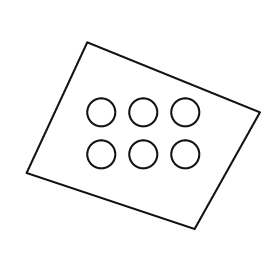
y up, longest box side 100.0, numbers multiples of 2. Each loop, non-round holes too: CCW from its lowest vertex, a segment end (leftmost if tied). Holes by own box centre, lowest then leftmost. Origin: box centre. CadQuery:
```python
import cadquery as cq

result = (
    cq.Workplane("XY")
    .moveTo(22.0, -40.0)
    .lineTo(50.0, 10.0)
    .lineTo(-24.0, 40.0)
    .lineTo(-50.0, -16.0)
    .close()
    .moveTo(-18.0, -8.0)
    .circle(6.0)
    .moveTo(0.0, -8.0)
    .circle(6.0)
    .moveTo(18.0, -8.0)
    .circle(6.0)
    .moveTo(-18.0, 10.0)
    .circle(6.0)
    .moveTo(0.0, 10.0)
    .circle(6.0)
    .moveTo(18.0, 10.0)
    .circle(6.0)
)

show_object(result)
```